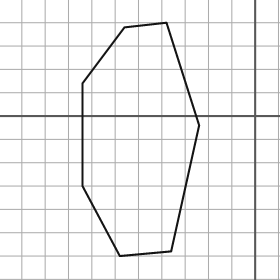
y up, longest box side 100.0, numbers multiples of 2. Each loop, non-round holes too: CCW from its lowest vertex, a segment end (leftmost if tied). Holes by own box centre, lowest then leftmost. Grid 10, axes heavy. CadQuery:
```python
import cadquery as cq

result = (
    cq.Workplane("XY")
    .moveTo(-58.0, -60.0)
    .lineTo(-36.0, -58.0)
    .lineTo(-24.0, -4.0)
    .lineTo(-38.0, 40.0)
    .lineTo(-56.0, 38.0)
    .lineTo(-74.0, 14.0)
    .lineTo(-74.0, -30.0)
    .close()
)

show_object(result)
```